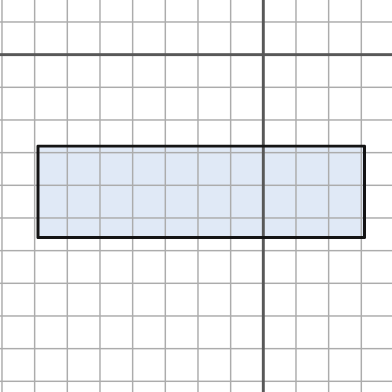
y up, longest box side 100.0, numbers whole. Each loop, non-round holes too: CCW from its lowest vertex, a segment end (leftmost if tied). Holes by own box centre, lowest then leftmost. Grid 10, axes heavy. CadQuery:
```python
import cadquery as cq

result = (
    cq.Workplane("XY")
    .moveTo(-69.0, -56.0)
    .lineTo(31.0, -56.0)
    .lineTo(31.0, -28.0)
    .lineTo(-69.0, -28.0)
    .close()
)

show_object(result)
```